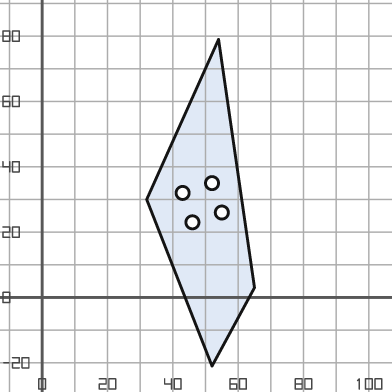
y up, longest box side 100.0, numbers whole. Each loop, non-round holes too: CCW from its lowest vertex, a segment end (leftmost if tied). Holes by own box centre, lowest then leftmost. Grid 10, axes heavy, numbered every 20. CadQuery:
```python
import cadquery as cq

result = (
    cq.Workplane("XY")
    .moveTo(52.0, -21.0)
    .lineTo(65.0, 3.0)
    .lineTo(54.0, 79.0)
    .lineTo(32.0, 30.0)
    .close()
    .moveTo(46.0, 23.0)
    .circle(2.0)
    .moveTo(55.0, 26.0)
    .circle(2.0)
    .moveTo(43.0, 32.0)
    .circle(2.0)
    .moveTo(52.0, 35.0)
    .circle(2.0)
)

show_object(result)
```